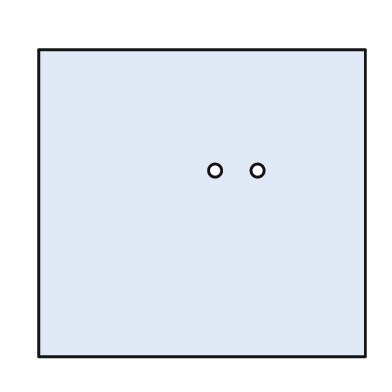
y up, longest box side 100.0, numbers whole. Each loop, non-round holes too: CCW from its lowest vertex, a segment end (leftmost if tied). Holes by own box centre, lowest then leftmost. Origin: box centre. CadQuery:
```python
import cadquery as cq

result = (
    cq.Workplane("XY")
    .moveTo(-50.0, -47.0)
    .lineTo(50.0, -47.0)
    .lineTo(50.0, 47.0)
    .lineTo(-50.0, 47.0)
    .close()
    .moveTo(4.0, 10.0)
    .circle(2.0)
    .moveTo(17.0, 10.0)
    .circle(2.0)
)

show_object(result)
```